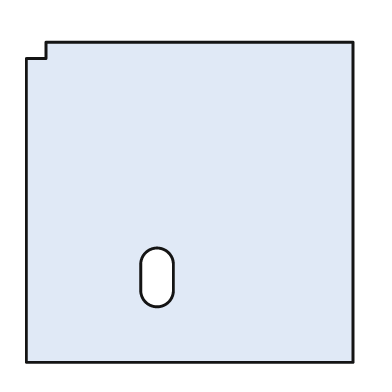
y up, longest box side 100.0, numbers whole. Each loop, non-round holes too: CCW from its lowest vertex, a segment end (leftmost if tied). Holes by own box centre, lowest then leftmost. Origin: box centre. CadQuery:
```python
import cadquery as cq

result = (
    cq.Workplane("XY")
    .moveTo(-50.0, -49.0)
    .lineTo(50.0, -49.0)
    .lineTo(50.0, 49.0)
    .lineTo(-44.0, 49.0)
    .lineTo(-44.0, 44.0)
    .lineTo(-50.0, 44.0)
    .close()
    .moveTo(-15.0, -27.0)
    .threePointArc((-10.0, -32.0), (-5.0, -27.0))
    .lineTo(-5.0, -19.0)
    .threePointArc((-10.0, -14.0), (-15.0, -19.0))
    .close()
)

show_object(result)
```